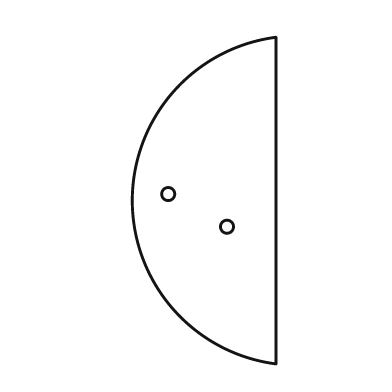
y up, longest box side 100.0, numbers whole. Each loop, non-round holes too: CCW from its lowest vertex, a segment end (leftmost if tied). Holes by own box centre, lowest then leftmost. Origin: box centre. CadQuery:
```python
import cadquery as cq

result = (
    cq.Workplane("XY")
    .moveTo(22.0, -50.0)
    .lineTo(22.0, 50.0)
    .threePointArc((-22.0, 0.0), (22.0, -50.0))
    .close()
    .moveTo(7.0, -8.0)
    .circle(2.0)
    .moveTo(-11.0, 2.0)
    .circle(2.0)
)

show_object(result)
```